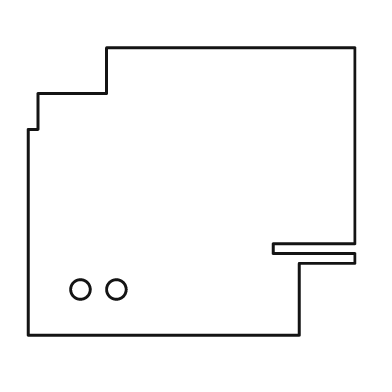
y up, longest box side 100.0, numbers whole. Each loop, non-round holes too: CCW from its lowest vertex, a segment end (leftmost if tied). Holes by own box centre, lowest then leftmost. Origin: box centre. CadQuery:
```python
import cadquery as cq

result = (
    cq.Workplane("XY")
    .moveTo(-50.0, -44.0)
    .lineTo(33.0, -44.0)
    .lineTo(33.0, -22.0)
    .lineTo(50.0, -22.0)
    .lineTo(50.0, -19.0)
    .lineTo(25.0, -19.0)
    .lineTo(25.0, -16.0)
    .lineTo(50.0, -16.0)
    .lineTo(50.0, 44.0)
    .lineTo(-26.0, 44.0)
    .lineTo(-26.0, 30.0)
    .lineTo(-47.0, 30.0)
    .lineTo(-47.0, 19.0)
    .lineTo(-50.0, 19.0)
    .close()
    .moveTo(-34.0, -30.0)
    .circle(3.0)
    .moveTo(-23.0, -30.0)
    .circle(3.0)
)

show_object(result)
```